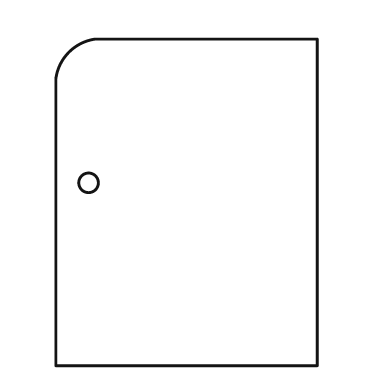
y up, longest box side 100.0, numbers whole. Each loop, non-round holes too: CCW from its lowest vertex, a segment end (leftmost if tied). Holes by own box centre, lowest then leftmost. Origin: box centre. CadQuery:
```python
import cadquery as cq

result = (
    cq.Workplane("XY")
    .moveTo(-40.0, -50.0)
    .lineTo(40.0, -50.0)
    .lineTo(40.0, 50.0)
    .lineTo(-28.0, 50.0)
    .threePointArc((-36.0, 46.0), (-40.0, 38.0))
    .close()
    .moveTo(-30.0, 6.0)
    .circle(3.0)
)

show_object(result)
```